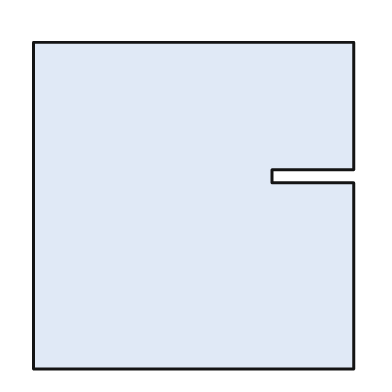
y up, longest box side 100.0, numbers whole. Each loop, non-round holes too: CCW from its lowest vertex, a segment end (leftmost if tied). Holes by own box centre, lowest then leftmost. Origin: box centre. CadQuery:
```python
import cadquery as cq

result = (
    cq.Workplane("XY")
    .moveTo(-49.0, -50.0)
    .lineTo(49.0, -50.0)
    .lineTo(49.0, 7.0)
    .lineTo(24.0, 7.0)
    .lineTo(24.0, 11.0)
    .lineTo(49.0, 11.0)
    .lineTo(49.0, 50.0)
    .lineTo(-49.0, 50.0)
    .close()
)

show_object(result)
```